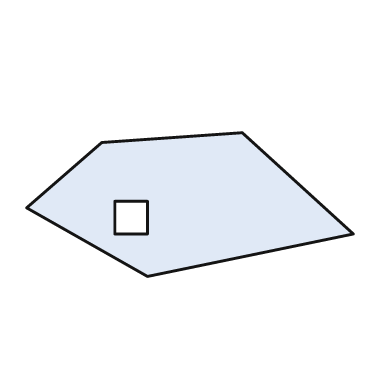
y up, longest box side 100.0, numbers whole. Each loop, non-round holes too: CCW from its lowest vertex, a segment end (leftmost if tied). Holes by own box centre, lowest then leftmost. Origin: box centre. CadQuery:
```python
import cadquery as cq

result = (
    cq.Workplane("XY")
    .moveTo(-13.0, -22.0)
    .lineTo(50.0, -9.0)
    .lineTo(16.0, 22.0)
    .lineTo(-27.0, 19.0)
    .lineTo(-50.0, -1.0)
    .close()
    .moveTo(-23.0, -9.0)
    .lineTo(-13.0, -9.0)
    .lineTo(-13.0, 1.0)
    .lineTo(-23.0, 1.0)
    .close()
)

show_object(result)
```